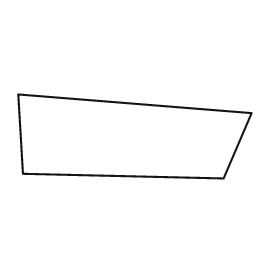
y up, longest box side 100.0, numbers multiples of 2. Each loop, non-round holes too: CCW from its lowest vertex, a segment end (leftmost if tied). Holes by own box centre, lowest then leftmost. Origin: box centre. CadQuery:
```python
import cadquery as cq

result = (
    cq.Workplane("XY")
    .moveTo(38.0, -18.0)
    .lineTo(50.0, 10.0)
    .lineTo(-50.0, 18.0)
    .lineTo(-48.0, -16.0)
    .close()
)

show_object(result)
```